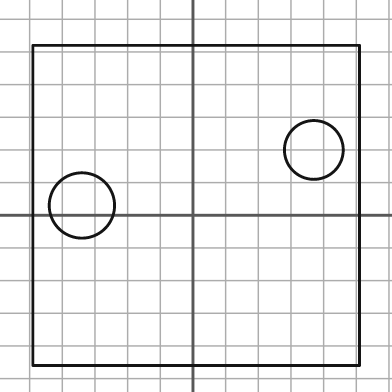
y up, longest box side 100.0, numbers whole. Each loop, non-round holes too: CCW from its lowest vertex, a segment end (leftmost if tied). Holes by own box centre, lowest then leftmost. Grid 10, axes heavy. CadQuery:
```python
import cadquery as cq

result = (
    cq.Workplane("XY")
    .moveTo(-49.0, -46.0)
    .lineTo(51.0, -46.0)
    .lineTo(51.0, 52.0)
    .lineTo(-49.0, 52.0)
    .close()
    .moveTo(-34.0, 3.0)
    .circle(10.0)
    .moveTo(37.0, 20.0)
    .circle(9.0)
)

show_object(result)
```